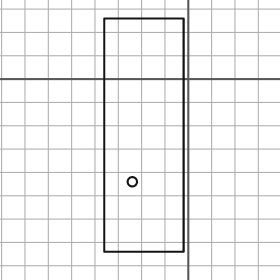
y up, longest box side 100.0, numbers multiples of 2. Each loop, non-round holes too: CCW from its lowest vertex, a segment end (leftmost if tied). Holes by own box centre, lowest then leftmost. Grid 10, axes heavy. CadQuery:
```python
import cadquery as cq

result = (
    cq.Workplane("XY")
    .moveTo(-36.0, -74.0)
    .lineTo(-2.0, -74.0)
    .lineTo(-2.0, 26.0)
    .lineTo(-36.0, 26.0)
    .close()
    .moveTo(-24.0, -44.0)
    .circle(2.0)
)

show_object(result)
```